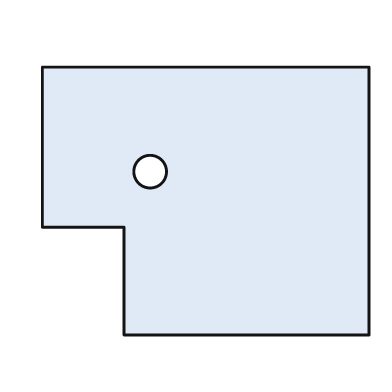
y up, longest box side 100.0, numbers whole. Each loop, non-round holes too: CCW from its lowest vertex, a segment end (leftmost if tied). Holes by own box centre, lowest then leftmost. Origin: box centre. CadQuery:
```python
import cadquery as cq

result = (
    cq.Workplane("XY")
    .moveTo(-25.0, -41.0)
    .lineTo(50.0, -41.0)
    .lineTo(50.0, 41.0)
    .lineTo(-50.0, 41.0)
    .lineTo(-50.0, -8.0)
    .lineTo(-25.0, -8.0)
    .close()
    .moveTo(-17.0, 9.0)
    .circle(5.0)
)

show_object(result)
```